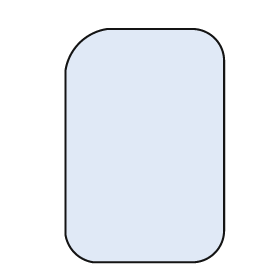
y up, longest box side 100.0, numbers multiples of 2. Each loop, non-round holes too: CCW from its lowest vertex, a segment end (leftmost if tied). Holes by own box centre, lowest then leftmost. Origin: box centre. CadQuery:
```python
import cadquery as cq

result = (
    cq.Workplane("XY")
    .moveTo(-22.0, -50.0)
    .lineTo(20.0, -50.0)
    .threePointArc((30.0, -46.0), (34.0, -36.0))
    .lineTo(34.0, 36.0)
    .threePointArc((30.0, 46.0), (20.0, 50.0))
    .lineTo(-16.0, 50.0)
    .threePointArc((-28.0, 44.0), (-34.0, 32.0))
    .lineTo(-34.0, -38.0)
    .threePointArc((-30.0, -46.0), (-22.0, -50.0))
    .close()
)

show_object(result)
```